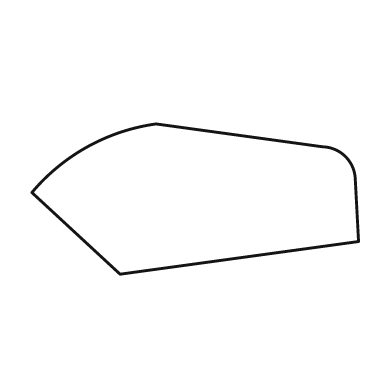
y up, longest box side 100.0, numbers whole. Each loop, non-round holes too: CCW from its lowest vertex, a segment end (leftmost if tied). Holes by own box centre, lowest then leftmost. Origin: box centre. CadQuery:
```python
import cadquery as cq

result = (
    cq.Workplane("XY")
    .moveTo(-23.0, -23.0)
    .lineTo(50.0, -13.0)
    .lineTo(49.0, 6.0)
    .threePointArc((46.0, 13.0), (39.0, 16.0))
    .lineTo(-12.0, 23.0)
    .threePointArc((-33.0, 16.0), (-50.0, 2.0))
    .close()
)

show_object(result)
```